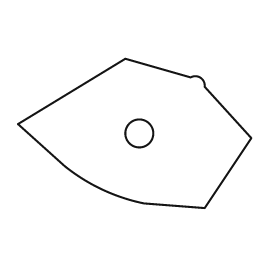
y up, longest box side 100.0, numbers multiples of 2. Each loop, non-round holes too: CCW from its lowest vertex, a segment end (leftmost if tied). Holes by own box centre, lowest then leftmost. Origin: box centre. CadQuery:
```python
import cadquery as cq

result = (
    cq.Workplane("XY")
    .moveTo(30.0, -32.0)
    .lineTo(50.0, -2.0)
    .lineTo(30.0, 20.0)
    .threePointArc((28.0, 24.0), (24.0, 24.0))
    .lineTo(-4.0, 32.0)
    .lineTo(-50.0, 4.0)
    .lineTo(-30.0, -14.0)
    .threePointArc((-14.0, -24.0), (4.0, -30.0))
    .close()
    .moveTo(2.0, 0.0)
    .circle(6.0)
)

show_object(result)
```